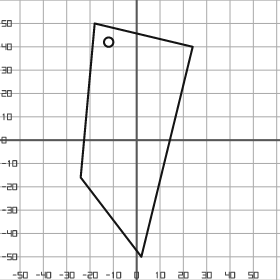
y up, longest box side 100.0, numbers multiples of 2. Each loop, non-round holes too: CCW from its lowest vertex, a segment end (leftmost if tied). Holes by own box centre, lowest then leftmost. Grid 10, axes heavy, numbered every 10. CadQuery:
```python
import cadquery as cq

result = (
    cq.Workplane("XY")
    .moveTo(2.0, -50.0)
    .lineTo(24.0, 40.0)
    .lineTo(-18.0, 50.0)
    .lineTo(-24.0, -16.0)
    .close()
    .moveTo(-12.0, 42.0)
    .circle(2.0)
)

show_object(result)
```